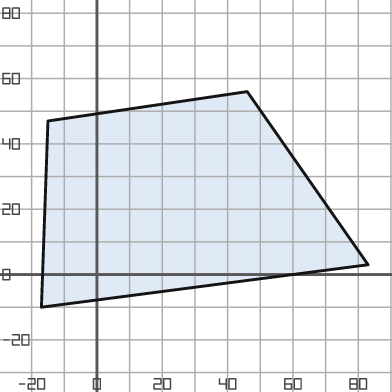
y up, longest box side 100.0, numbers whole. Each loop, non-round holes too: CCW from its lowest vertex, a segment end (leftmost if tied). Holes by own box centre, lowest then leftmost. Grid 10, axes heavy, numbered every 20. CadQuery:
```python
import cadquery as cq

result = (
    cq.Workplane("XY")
    .moveTo(-17.0, -10.0)
    .lineTo(83.0, 3.0)
    .lineTo(46.0, 56.0)
    .lineTo(-15.0, 47.0)
    .close()
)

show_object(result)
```